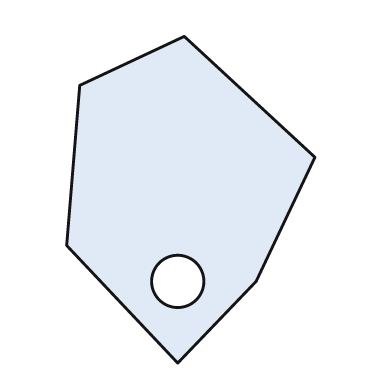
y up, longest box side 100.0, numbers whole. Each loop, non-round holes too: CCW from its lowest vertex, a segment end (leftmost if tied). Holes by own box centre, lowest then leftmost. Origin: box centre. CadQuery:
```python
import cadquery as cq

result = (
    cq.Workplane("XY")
    .moveTo(-4.0, -50.0)
    .lineTo(20.0, -25.0)
    .lineTo(38.0, 13.0)
    .lineTo(-2.0, 50.0)
    .lineTo(-34.0, 35.0)
    .lineTo(-38.0, -14.0)
    .close()
    .moveTo(-4.0, -25.0)
    .circle(8.0)
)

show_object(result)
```